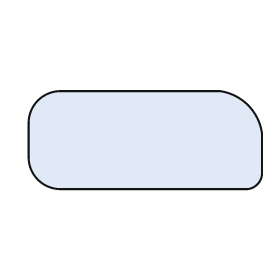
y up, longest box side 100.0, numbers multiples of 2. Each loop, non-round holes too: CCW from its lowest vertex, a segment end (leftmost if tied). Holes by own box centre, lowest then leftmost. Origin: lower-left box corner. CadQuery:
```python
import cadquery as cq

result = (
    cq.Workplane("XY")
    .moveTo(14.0, 0.0)
    .lineTo(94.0, 0.0)
    .threePointArc((98.0, 2.0), (100.0, 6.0))
    .lineTo(100.0, 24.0)
    .threePointArc((94.0, 36.0), (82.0, 42.0))
    .lineTo(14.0, 42.0)
    .threePointArc((4.0, 38.0), (0.0, 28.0))
    .lineTo(0.0, 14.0)
    .threePointArc((4.0, 4.0), (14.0, 0.0))
    .close()
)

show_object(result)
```